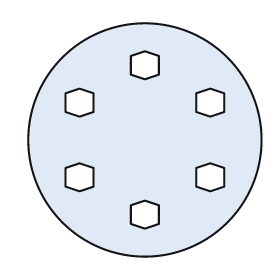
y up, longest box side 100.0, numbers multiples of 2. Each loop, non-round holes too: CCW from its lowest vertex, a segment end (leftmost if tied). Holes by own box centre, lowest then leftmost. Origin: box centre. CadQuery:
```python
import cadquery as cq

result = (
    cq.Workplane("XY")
    .moveTo(0.0, 0.0)
    .circle(50.0)
    .moveTo(0.0, -38.0)
    .lineTo(6.0, -36.0)
    .lineTo(6.0, -28.0)
    .lineTo(0.0, -26.0)
    .lineTo(-6.0, -28.0)
    .lineTo(-6.0, -36.0)
    .close()
    .moveTo(-28.0, -22.0)
    .lineTo(-22.0, -20.0)
    .lineTo(-22.0, -12.0)
    .lineTo(-28.0, -10.0)
    .lineTo(-34.0, -12.0)
    .lineTo(-34.0, -20.0)
    .close()
    .moveTo(28.0, -22.0)
    .lineTo(34.0, -20.0)
    .lineTo(34.0, -12.0)
    .lineTo(28.0, -10.0)
    .lineTo(22.0, -12.0)
    .lineTo(22.0, -20.0)
    .close()
    .moveTo(-28.0, 10.0)
    .lineTo(-22.0, 12.0)
    .lineTo(-22.0, 20.0)
    .lineTo(-28.0, 22.0)
    .lineTo(-34.0, 20.0)
    .lineTo(-34.0, 12.0)
    .close()
    .moveTo(28.0, 10.0)
    .lineTo(34.0, 12.0)
    .lineTo(34.0, 20.0)
    .lineTo(28.0, 22.0)
    .lineTo(22.0, 20.0)
    .lineTo(22.0, 12.0)
    .close()
    .moveTo(0.0, 26.0)
    .lineTo(6.0, 28.0)
    .lineTo(6.0, 36.0)
    .lineTo(0.0, 38.0)
    .lineTo(-6.0, 36.0)
    .lineTo(-6.0, 28.0)
    .close()
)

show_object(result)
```